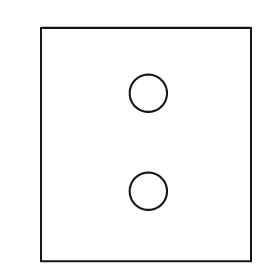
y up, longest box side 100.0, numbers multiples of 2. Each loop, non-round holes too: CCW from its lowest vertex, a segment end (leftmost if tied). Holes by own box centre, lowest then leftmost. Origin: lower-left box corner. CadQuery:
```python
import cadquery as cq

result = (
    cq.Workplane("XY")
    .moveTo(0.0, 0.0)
    .lineTo(90.0, 0.0)
    .lineTo(90.0, 100.0)
    .lineTo(0.0, 100.0)
    .close()
    .moveTo(46.0, 30.0)
    .circle(8.0)
    .moveTo(46.0, 72.0)
    .circle(8.0)
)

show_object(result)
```